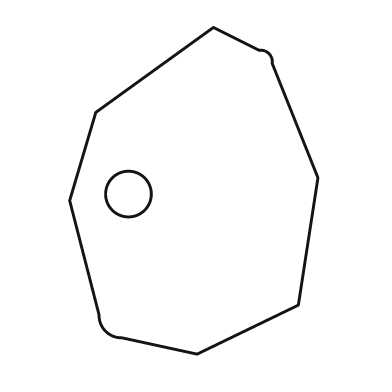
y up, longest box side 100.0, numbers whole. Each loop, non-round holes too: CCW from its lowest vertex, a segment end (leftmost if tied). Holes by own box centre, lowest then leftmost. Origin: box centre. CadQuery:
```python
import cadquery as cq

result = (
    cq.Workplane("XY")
    .moveTo(1.0, -50.0)
    .lineTo(32.0, -35.0)
    .lineTo(38.0, 4.0)
    .lineTo(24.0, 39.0)
    .threePointArc((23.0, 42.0), (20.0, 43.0))
    .lineTo(6.0, 50.0)
    .lineTo(-30.0, 24.0)
    .lineTo(-38.0, -3.0)
    .lineTo(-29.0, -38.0)
    .threePointArc((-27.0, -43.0), (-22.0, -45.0))
    .close()
    .moveTo(-20.0, -1.0)
    .circle(7.0)
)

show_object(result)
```